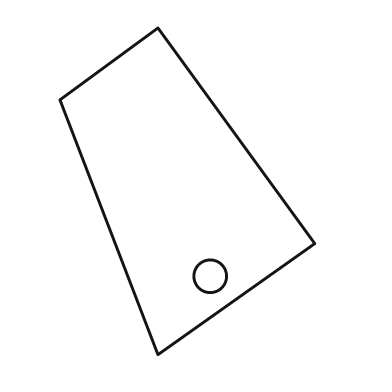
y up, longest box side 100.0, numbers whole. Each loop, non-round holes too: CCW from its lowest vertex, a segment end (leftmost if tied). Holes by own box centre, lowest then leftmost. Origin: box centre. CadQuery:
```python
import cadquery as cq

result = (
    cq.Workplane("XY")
    .moveTo(-9.0, -50.0)
    .lineTo(39.0, -16.0)
    .lineTo(-9.0, 50.0)
    .lineTo(-39.0, 28.0)
    .close()
    .moveTo(7.0, -26.0)
    .circle(5.0)
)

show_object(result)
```